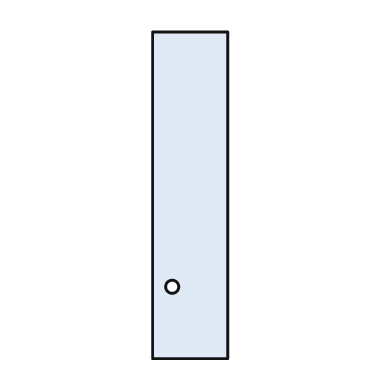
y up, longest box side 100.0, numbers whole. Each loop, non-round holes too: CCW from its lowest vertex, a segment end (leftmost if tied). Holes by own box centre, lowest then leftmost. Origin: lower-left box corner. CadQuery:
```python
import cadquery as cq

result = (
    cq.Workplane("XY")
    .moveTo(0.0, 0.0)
    .lineTo(23.0, 0.0)
    .lineTo(23.0, 100.0)
    .lineTo(0.0, 100.0)
    .close()
    .moveTo(6.0, 22.0)
    .circle(2.0)
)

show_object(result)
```